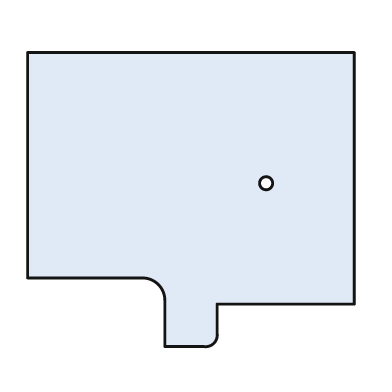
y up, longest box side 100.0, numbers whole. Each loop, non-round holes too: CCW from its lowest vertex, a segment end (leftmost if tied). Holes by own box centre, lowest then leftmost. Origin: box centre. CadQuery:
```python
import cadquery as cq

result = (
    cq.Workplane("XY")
    .moveTo(-8.0, -45.0)
    .lineTo(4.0, -45.0)
    .threePointArc((7.0, -44.0), (8.0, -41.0))
    .lineTo(8.0, -32.0)
    .lineTo(50.0, -32.0)
    .lineTo(50.0, 45.0)
    .lineTo(-50.0, 45.0)
    .lineTo(-50.0, -24.0)
    .lineTo(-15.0, -24.0)
    .threePointArc((-10.0, -26.0), (-8.0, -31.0))
    .close()
    .moveTo(23.0, 5.0)
    .circle(2.0)
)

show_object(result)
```